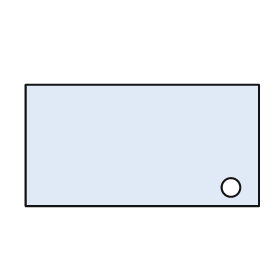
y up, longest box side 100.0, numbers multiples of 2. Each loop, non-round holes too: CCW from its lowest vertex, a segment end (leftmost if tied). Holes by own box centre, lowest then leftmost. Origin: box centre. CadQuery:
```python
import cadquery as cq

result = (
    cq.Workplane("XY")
    .moveTo(-50.0, -26.0)
    .lineTo(50.0, -26.0)
    .lineTo(50.0, 26.0)
    .lineTo(-50.0, 26.0)
    .close()
    .moveTo(38.0, -18.0)
    .circle(4.0)
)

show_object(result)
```